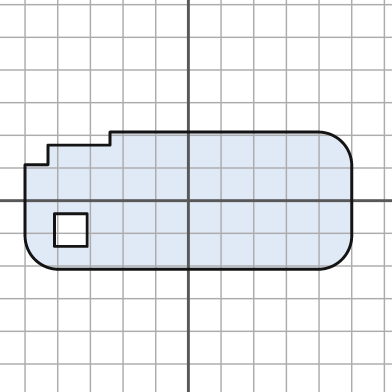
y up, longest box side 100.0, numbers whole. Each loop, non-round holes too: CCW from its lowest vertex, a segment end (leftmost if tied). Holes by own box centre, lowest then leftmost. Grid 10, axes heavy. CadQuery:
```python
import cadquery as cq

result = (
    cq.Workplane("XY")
    .moveTo(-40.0, -21.0)
    .lineTo(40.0, -21.0)
    .threePointArc((47.0, -18.0), (50.0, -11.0))
    .lineTo(50.0, 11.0)
    .threePointArc((47.0, 18.0), (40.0, 21.0))
    .lineTo(-24.0, 21.0)
    .lineTo(-24.0, 17.0)
    .lineTo(-43.0, 17.0)
    .lineTo(-43.0, 11.0)
    .lineTo(-50.0, 11.0)
    .lineTo(-50.0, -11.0)
    .threePointArc((-47.0, -18.0), (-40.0, -21.0))
    .close()
    .moveTo(-41.0, -14.0)
    .lineTo(-31.0, -14.0)
    .lineTo(-31.0, -4.0)
    .lineTo(-41.0, -4.0)
    .close()
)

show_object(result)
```